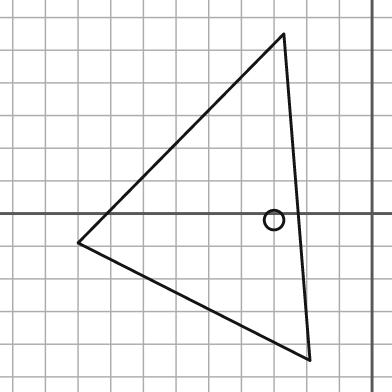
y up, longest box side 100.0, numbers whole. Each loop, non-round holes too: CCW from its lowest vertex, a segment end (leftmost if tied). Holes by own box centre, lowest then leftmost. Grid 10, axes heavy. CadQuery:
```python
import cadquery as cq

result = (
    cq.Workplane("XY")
    .moveTo(-19.0, -45.0)
    .lineTo(-27.0, 55.0)
    .lineTo(-90.0, -9.0)
    .close()
    .moveTo(-30.0, -2.0)
    .circle(3.0)
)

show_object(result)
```